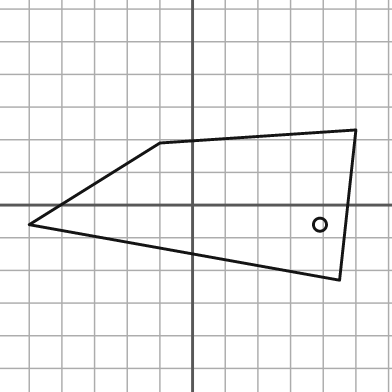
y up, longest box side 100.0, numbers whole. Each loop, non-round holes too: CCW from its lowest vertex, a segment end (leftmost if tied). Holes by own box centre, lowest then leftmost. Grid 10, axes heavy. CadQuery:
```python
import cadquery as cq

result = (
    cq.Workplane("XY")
    .moveTo(45.0, -23.0)
    .lineTo(50.0, 23.0)
    .lineTo(-10.0, 19.0)
    .lineTo(-50.0, -6.0)
    .close()
    .moveTo(39.0, -6.0)
    .circle(2.0)
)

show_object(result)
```